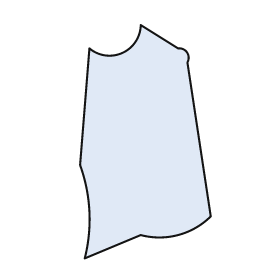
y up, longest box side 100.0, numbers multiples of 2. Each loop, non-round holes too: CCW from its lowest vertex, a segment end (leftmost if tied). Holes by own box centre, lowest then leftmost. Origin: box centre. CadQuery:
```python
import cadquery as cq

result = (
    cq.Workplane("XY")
    .moveTo(-26.0, -50.0)
    .lineTo(-2.0, -40.0)
    .threePointArc((14.0, -40.0), (28.0, -32.0))
    .lineTo(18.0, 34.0)
    .threePointArc((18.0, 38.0), (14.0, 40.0))
    .lineTo(-2.0, 50.0)
    .threePointArc((-10.0, 38.0), (-24.0, 40.0))
    .lineTo(-28.0, -10.0)
    .threePointArc((-24.0, -30.0), (-26.0, -50.0))
    .close()
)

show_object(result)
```